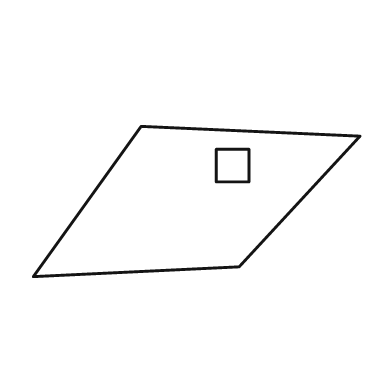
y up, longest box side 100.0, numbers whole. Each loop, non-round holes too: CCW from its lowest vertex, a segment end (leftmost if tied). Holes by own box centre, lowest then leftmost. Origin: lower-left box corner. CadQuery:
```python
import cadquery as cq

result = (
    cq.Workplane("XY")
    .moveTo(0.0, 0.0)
    .lineTo(63.0, 3.0)
    .lineTo(100.0, 43.0)
    .lineTo(33.0, 46.0)
    .close()
    .moveTo(56.0, 29.0)
    .lineTo(66.0, 29.0)
    .lineTo(66.0, 39.0)
    .lineTo(56.0, 39.0)
    .close()
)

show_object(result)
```